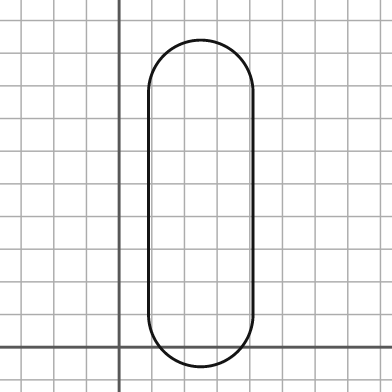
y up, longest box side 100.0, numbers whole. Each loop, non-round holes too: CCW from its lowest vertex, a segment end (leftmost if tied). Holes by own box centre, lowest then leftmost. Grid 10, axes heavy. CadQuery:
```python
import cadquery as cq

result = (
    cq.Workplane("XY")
    .moveTo(9.0, 10.0)
    .threePointArc((25.0, -6.0), (41.0, 10.0))
    .lineTo(41.0, 78.0)
    .threePointArc((25.0, 94.0), (9.0, 78.0))
    .close()
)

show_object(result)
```